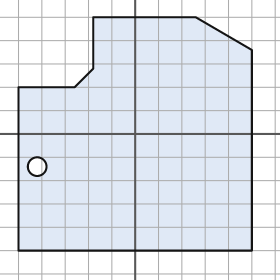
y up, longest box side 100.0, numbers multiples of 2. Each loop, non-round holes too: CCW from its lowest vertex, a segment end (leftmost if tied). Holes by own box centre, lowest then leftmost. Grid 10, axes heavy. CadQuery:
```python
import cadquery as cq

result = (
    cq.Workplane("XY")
    .moveTo(-50.0, -50.0)
    .lineTo(50.0, -50.0)
    .lineTo(50.0, 36.0)
    .lineTo(26.0, 50.0)
    .lineTo(-18.0, 50.0)
    .lineTo(-18.0, 28.0)
    .lineTo(-26.0, 20.0)
    .lineTo(-50.0, 20.0)
    .close()
    .moveTo(-42.0, -14.0)
    .circle(4.0)
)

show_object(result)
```